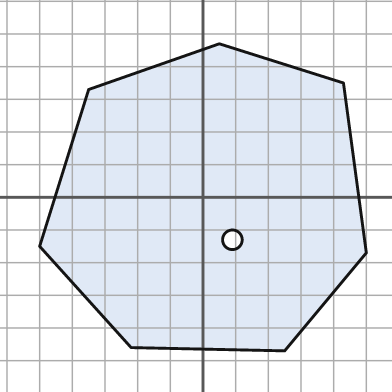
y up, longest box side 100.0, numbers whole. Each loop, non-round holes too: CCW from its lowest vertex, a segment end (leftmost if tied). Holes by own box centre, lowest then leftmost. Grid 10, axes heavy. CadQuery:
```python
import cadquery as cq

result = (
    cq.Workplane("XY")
    .moveTo(25.0, -47.0)
    .lineTo(50.0, -17.0)
    .lineTo(43.0, 35.0)
    .lineTo(5.0, 47.0)
    .lineTo(-35.0, 33.0)
    .lineTo(-50.0, -15.0)
    .lineTo(-22.0, -46.0)
    .close()
    .moveTo(9.0, -13.0)
    .circle(3.0)
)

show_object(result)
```